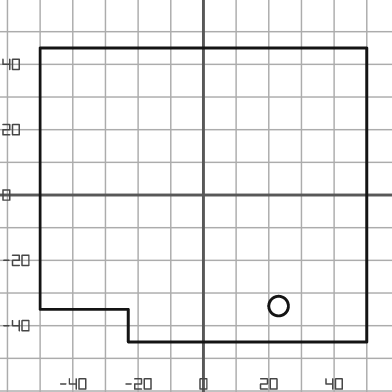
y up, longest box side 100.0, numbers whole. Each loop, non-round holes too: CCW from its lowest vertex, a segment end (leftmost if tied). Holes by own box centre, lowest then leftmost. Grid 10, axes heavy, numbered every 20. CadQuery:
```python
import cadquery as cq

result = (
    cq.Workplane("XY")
    .moveTo(-23.0, -45.0)
    .lineTo(50.0, -45.0)
    .lineTo(50.0, 45.0)
    .lineTo(-50.0, 45.0)
    .lineTo(-50.0, -35.0)
    .lineTo(-23.0, -35.0)
    .close()
    .moveTo(23.0, -34.0)
    .circle(3.0)
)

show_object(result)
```